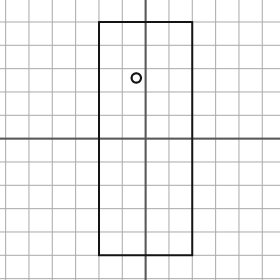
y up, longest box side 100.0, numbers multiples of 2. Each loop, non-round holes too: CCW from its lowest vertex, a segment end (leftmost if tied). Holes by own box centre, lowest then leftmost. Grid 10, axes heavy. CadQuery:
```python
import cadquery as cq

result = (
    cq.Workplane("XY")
    .moveTo(-20.0, -50.0)
    .lineTo(20.0, -50.0)
    .lineTo(20.0, 50.0)
    .lineTo(-20.0, 50.0)
    .close()
    .moveTo(-4.0, 26.0)
    .circle(2.0)
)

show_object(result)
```